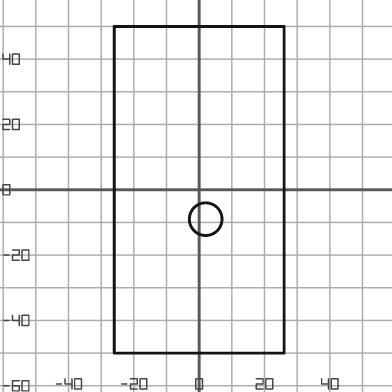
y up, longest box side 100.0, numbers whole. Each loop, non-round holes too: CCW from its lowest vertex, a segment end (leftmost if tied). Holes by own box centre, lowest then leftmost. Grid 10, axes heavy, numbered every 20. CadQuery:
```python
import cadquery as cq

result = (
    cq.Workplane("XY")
    .moveTo(-26.0, -50.0)
    .lineTo(26.0, -50.0)
    .lineTo(26.0, 50.0)
    .lineTo(-26.0, 50.0)
    .close()
    .moveTo(2.0, -9.0)
    .circle(5.0)
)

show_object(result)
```